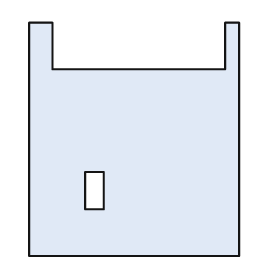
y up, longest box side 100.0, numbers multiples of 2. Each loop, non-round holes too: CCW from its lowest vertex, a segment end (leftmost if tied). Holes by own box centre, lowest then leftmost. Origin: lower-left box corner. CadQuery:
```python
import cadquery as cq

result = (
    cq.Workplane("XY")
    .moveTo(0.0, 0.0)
    .lineTo(90.0, 0.0)
    .lineTo(90.0, 100.0)
    .lineTo(84.0, 100.0)
    .lineTo(84.0, 80.0)
    .lineTo(10.0, 80.0)
    .lineTo(10.0, 100.0)
    .lineTo(0.0, 100.0)
    .close()
    .moveTo(24.0, 20.0)
    .lineTo(32.0, 20.0)
    .lineTo(32.0, 36.0)
    .lineTo(24.0, 36.0)
    .close()
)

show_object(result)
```